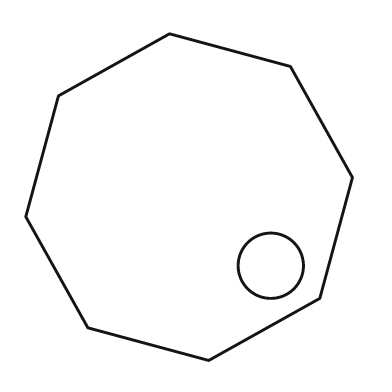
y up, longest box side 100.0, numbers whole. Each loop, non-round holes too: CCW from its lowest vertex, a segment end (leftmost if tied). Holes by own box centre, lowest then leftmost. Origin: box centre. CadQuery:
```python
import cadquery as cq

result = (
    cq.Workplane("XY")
    .moveTo(6.0, -50.0)
    .lineTo(40.0, -31.0)
    .lineTo(50.0, 6.0)
    .lineTo(31.0, 40.0)
    .lineTo(-6.0, 50.0)
    .lineTo(-40.0, 31.0)
    .lineTo(-50.0, -6.0)
    .lineTo(-31.0, -40.0)
    .close()
    .moveTo(25.0, -21.0)
    .circle(10.0)
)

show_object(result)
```